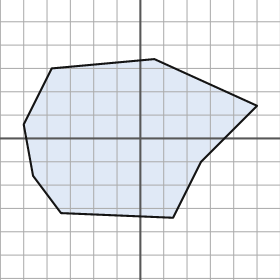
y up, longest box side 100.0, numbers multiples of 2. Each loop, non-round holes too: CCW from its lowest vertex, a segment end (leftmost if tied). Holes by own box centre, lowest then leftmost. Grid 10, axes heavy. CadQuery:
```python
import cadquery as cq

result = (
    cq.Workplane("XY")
    .moveTo(14.0, -34.0)
    .lineTo(26.0, -10.0)
    .lineTo(50.0, 14.0)
    .lineTo(6.0, 34.0)
    .lineTo(-38.0, 30.0)
    .lineTo(-50.0, 6.0)
    .lineTo(-46.0, -16.0)
    .lineTo(-34.0, -32.0)
    .close()
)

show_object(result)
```